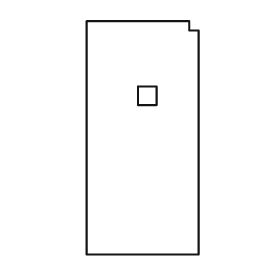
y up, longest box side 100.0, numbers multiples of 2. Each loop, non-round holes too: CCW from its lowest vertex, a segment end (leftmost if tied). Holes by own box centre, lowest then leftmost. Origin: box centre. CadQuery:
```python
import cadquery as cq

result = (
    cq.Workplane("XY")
    .moveTo(-24.0, -50.0)
    .lineTo(24.0, -50.0)
    .lineTo(24.0, 46.0)
    .lineTo(20.0, 46.0)
    .lineTo(20.0, 50.0)
    .lineTo(-24.0, 50.0)
    .close()
    .moveTo(-2.0, 14.0)
    .lineTo(6.0, 14.0)
    .lineTo(6.0, 22.0)
    .lineTo(-2.0, 22.0)
    .close()
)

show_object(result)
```